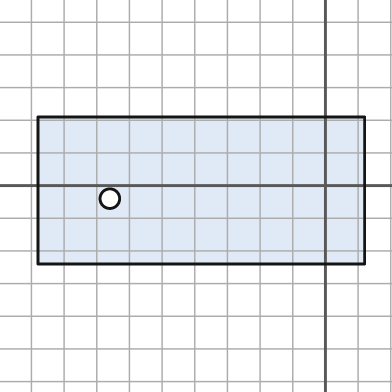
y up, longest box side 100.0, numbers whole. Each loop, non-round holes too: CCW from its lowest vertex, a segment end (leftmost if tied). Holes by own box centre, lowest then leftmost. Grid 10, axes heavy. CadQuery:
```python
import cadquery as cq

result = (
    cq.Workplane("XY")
    .moveTo(-88.0, -24.0)
    .lineTo(12.0, -24.0)
    .lineTo(12.0, 21.0)
    .lineTo(-88.0, 21.0)
    .close()
    .moveTo(-66.0, -4.0)
    .circle(3.0)
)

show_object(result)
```